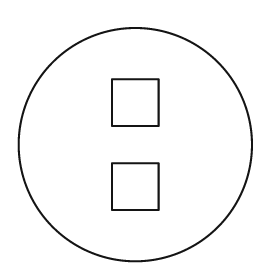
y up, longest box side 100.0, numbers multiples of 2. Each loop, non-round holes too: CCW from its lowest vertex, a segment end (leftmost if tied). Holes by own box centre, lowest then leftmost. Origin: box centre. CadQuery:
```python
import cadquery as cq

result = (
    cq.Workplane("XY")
    .moveTo(0.0, 0.0)
    .circle(50.0)
    .moveTo(-10.0, -28.0)
    .lineTo(10.0, -28.0)
    .lineTo(10.0, -8.0)
    .lineTo(-10.0, -8.0)
    .close()
    .moveTo(-10.0, 8.0)
    .lineTo(10.0, 8.0)
    .lineTo(10.0, 28.0)
    .lineTo(-10.0, 28.0)
    .close()
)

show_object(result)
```